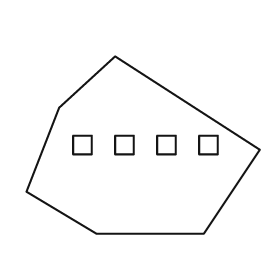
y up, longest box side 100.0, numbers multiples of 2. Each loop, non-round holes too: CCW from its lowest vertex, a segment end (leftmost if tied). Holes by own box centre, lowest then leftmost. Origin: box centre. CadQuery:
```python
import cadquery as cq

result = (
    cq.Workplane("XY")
    .moveTo(-20.0, -38.0)
    .lineTo(26.0, -38.0)
    .lineTo(50.0, -2.0)
    .lineTo(-12.0, 38.0)
    .lineTo(-36.0, 16.0)
    .lineTo(-50.0, -20.0)
    .close()
    .moveTo(-30.0, -4.0)
    .lineTo(-22.0, -4.0)
    .lineTo(-22.0, 4.0)
    .lineTo(-30.0, 4.0)
    .close()
    .moveTo(-12.0, -4.0)
    .lineTo(-4.0, -4.0)
    .lineTo(-4.0, 4.0)
    .lineTo(-12.0, 4.0)
    .close()
    .moveTo(6.0, -4.0)
    .lineTo(14.0, -4.0)
    .lineTo(14.0, 4.0)
    .lineTo(6.0, 4.0)
    .close()
    .moveTo(24.0, -4.0)
    .lineTo(32.0, -4.0)
    .lineTo(32.0, 4.0)
    .lineTo(24.0, 4.0)
    .close()
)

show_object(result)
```